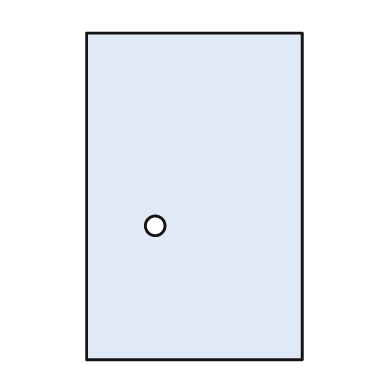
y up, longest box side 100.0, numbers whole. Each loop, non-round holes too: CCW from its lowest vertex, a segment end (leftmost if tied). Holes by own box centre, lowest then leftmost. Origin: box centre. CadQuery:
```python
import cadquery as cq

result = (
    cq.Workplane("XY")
    .moveTo(-33.0, -50.0)
    .lineTo(33.0, -50.0)
    .lineTo(33.0, 50.0)
    .lineTo(-33.0, 50.0)
    .close()
    .moveTo(-12.0, -9.0)
    .circle(3.0)
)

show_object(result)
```